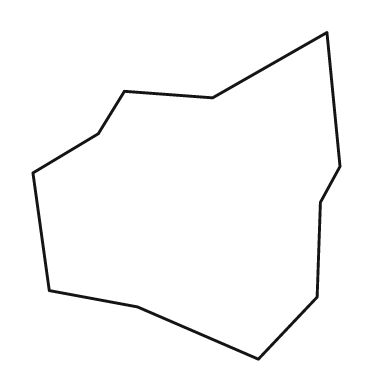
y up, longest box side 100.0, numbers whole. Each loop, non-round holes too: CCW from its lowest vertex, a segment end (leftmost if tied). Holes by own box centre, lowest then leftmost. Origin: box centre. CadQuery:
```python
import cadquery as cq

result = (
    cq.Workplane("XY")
    .moveTo(22.0, -50.0)
    .lineTo(40.0, -31.0)
    .lineTo(41.0, -2.0)
    .lineTo(47.0, 9.0)
    .lineTo(43.0, 50.0)
    .lineTo(8.0, 30.0)
    .lineTo(-19.0, 32.0)
    .lineTo(-27.0, 19.0)
    .lineTo(-47.0, 7.0)
    .lineTo(-42.0, -29.0)
    .lineTo(-15.0, -34.0)
    .close()
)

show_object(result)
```